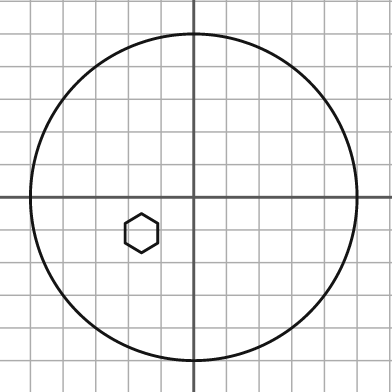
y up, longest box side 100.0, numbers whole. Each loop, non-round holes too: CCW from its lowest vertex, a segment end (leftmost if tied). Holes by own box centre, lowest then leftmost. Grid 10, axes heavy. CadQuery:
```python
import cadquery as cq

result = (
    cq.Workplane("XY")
    .moveTo(0.0, 0.0)
    .circle(50.0)
    .moveTo(-16.0, -17.0)
    .lineTo(-11.0, -14.0)
    .lineTo(-11.0, -8.0)
    .lineTo(-16.0, -5.0)
    .lineTo(-21.0, -8.0)
    .lineTo(-21.0, -14.0)
    .close()
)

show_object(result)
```